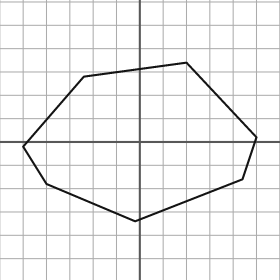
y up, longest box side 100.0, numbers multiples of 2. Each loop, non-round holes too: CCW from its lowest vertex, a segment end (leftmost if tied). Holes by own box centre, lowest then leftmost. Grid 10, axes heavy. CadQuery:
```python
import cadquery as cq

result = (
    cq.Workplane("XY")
    .moveTo(-2.0, -34.0)
    .lineTo(44.0, -16.0)
    .lineTo(50.0, 2.0)
    .lineTo(20.0, 34.0)
    .lineTo(-24.0, 28.0)
    .lineTo(-50.0, -2.0)
    .lineTo(-40.0, -18.0)
    .close()
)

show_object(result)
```